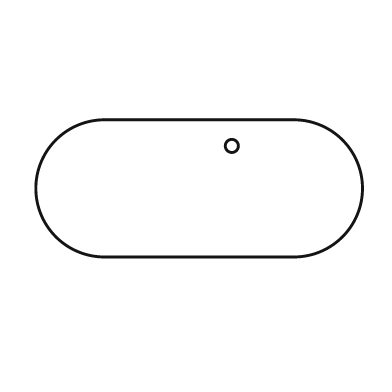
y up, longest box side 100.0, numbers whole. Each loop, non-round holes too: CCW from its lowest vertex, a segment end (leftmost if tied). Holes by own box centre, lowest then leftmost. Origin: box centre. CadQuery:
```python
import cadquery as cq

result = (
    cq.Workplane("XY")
    .moveTo(-29.0, -21.0)
    .lineTo(29.0, -21.0)
    .threePointArc((50.0, 0.0), (29.0, 21.0))
    .lineTo(-29.0, 21.0)
    .threePointArc((-50.0, 0.0), (-29.0, -21.0))
    .close()
    .moveTo(10.0, 13.0)
    .circle(2.0)
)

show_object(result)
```